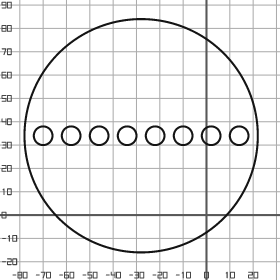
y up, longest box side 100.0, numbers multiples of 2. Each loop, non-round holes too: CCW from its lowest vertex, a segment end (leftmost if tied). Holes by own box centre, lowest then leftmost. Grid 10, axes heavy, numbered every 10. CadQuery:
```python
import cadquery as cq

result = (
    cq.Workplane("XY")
    .moveTo(-28.0, 34.0)
    .circle(50.0)
    .moveTo(-70.0, 34.0)
    .circle(4.0)
    .moveTo(-58.0, 34.0)
    .circle(4.0)
    .moveTo(-46.0, 34.0)
    .circle(4.0)
    .moveTo(-34.0, 34.0)
    .circle(4.0)
    .moveTo(-22.0, 34.0)
    .circle(4.0)
    .moveTo(-10.0, 34.0)
    .circle(4.0)
    .moveTo(2.0, 34.0)
    .circle(4.0)
    .moveTo(14.0, 34.0)
    .circle(4.0)
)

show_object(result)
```